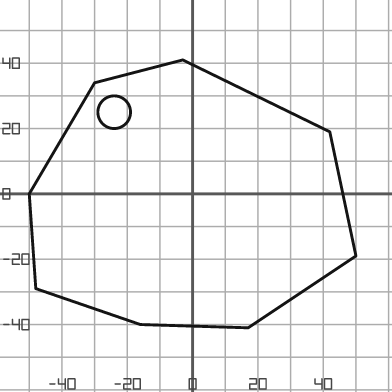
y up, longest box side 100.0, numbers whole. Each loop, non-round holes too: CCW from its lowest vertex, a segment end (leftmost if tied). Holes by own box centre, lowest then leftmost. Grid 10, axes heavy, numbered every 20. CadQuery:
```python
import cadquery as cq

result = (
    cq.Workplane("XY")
    .moveTo(17.0, -41.0)
    .lineTo(50.0, -19.0)
    .lineTo(42.0, 19.0)
    .lineTo(-3.0, 41.0)
    .lineTo(-30.0, 34.0)
    .lineTo(-50.0, 0.0)
    .lineTo(-48.0, -29.0)
    .lineTo(-16.0, -40.0)
    .close()
    .moveTo(-24.0, 25.0)
    .circle(5.0)
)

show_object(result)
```